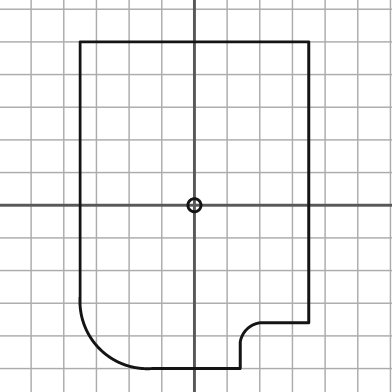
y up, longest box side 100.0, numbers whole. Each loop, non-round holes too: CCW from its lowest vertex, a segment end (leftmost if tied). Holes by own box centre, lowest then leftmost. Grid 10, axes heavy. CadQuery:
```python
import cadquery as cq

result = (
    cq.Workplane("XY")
    .moveTo(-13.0, -50.0)
    .lineTo(14.0, -50.0)
    .lineTo(14.0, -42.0)
    .threePointArc((16.0, -38.0), (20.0, -36.0))
    .lineTo(35.0, -36.0)
    .lineTo(35.0, 50.0)
    .lineTo(-35.0, 50.0)
    .lineTo(-35.0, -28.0)
    .threePointArc((-29.0, -44.0), (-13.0, -50.0))
    .close()
    .moveTo(0.0, 0.0)
    .circle(2.0)
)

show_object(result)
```